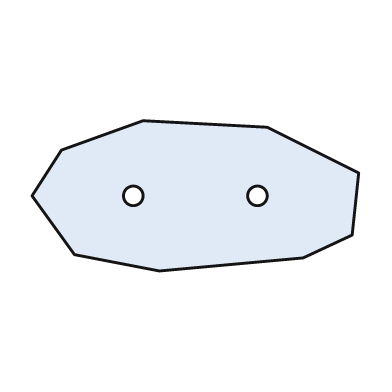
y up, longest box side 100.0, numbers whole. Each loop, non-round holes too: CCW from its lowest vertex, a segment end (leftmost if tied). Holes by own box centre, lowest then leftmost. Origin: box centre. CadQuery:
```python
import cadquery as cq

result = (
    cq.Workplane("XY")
    .moveTo(-11.0, -23.0)
    .lineTo(33.0, -19.0)
    .lineTo(48.0, -12.0)
    .lineTo(50.0, 7.0)
    .lineTo(22.0, 21.0)
    .lineTo(-16.0, 23.0)
    .lineTo(-41.0, 14.0)
    .lineTo(-50.0, 0.0)
    .lineTo(-37.0, -18.0)
    .close()
    .moveTo(-19.0, 0.0)
    .circle(3.0)
    .moveTo(19.0, 0.0)
    .circle(3.0)
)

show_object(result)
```